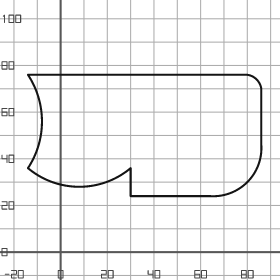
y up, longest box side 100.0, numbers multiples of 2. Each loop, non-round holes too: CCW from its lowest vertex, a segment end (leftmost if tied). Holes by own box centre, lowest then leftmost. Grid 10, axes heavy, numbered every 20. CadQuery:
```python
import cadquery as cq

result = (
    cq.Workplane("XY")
    .moveTo(30.0, 24.0)
    .lineTo(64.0, 24.0)
    .threePointArc((80.0, 30.0), (86.0, 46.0))
    .lineTo(86.0, 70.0)
    .threePointArc((84.0, 74.0), (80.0, 76.0))
    .lineTo(-14.0, 76.0)
    .threePointArc((-8.0, 56.0), (-14.0, 36.0))
    .threePointArc((8.0, 28.0), (30.0, 36.0))
    .close()
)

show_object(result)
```